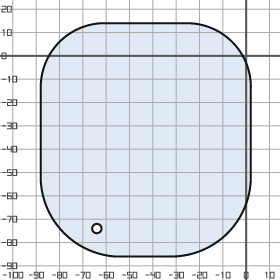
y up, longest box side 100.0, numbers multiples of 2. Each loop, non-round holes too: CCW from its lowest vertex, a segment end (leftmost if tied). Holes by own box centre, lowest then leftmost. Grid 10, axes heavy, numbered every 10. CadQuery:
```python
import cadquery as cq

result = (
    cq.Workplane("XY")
    .moveTo(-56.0, -86.0)
    .lineTo(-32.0, -86.0)
    .threePointArc((-8.0, -76.0), (2.0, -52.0))
    .lineTo(2.0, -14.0)
    .threePointArc((-6.0, 6.0), (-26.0, 14.0))
    .lineTo(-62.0, 14.0)
    .threePointArc((-80.0, 6.0), (-88.0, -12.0))
    .lineTo(-88.0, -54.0)
    .threePointArc((-78.0, -76.0), (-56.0, -86.0))
    .close()
    .moveTo(-64.0, -74.0)
    .circle(2.0)
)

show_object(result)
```